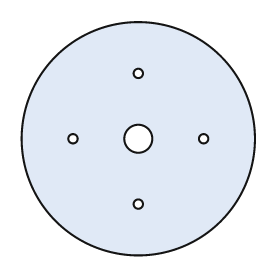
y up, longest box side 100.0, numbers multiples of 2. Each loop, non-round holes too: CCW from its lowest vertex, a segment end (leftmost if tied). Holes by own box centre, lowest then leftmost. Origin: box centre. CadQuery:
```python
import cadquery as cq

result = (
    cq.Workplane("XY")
    .moveTo(0.0, 0.0)
    .circle(50.0)
    .moveTo(0.0, -28.0)
    .circle(2.0)
    .moveTo(-28.0, 0.0)
    .circle(2.0)
    .moveTo(0.0, 0.0)
    .circle(6.0)
    .moveTo(28.0, 0.0)
    .circle(2.0)
    .moveTo(0.0, 28.0)
    .circle(2.0)
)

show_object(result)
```